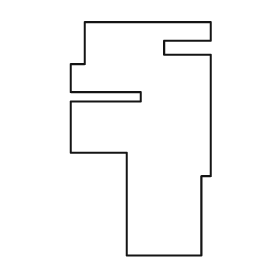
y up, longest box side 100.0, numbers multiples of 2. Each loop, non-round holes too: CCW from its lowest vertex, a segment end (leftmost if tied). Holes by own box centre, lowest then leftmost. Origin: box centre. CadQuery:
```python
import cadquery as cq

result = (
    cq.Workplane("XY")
    .moveTo(-6.0, -50.0)
    .lineTo(26.0, -50.0)
    .lineTo(26.0, -16.0)
    .lineTo(30.0, -16.0)
    .lineTo(30.0, 36.0)
    .lineTo(10.0, 36.0)
    .lineTo(10.0, 42.0)
    .lineTo(30.0, 42.0)
    .lineTo(30.0, 50.0)
    .lineTo(-24.0, 50.0)
    .lineTo(-24.0, 32.0)
    .lineTo(-30.0, 32.0)
    .lineTo(-30.0, 20.0)
    .lineTo(0.0, 20.0)
    .lineTo(0.0, 16.0)
    .lineTo(-30.0, 16.0)
    .lineTo(-30.0, -6.0)
    .lineTo(-6.0, -6.0)
    .close()
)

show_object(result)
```